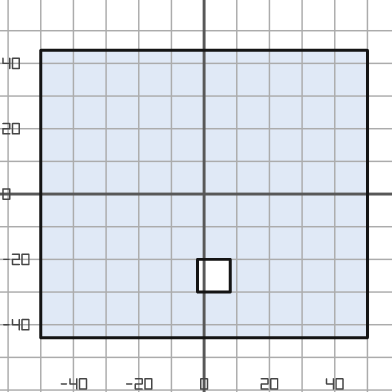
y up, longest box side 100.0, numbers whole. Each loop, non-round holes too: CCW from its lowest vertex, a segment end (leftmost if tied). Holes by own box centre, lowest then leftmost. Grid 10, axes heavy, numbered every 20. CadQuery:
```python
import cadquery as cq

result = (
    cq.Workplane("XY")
    .moveTo(-50.0, -44.0)
    .lineTo(50.0, -44.0)
    .lineTo(50.0, 44.0)
    .lineTo(-50.0, 44.0)
    .close()
    .moveTo(-2.0, -30.0)
    .lineTo(8.0, -30.0)
    .lineTo(8.0, -20.0)
    .lineTo(-2.0, -20.0)
    .close()
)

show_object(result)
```